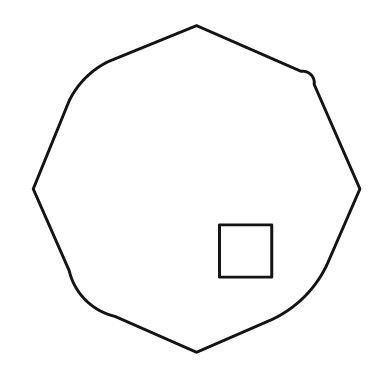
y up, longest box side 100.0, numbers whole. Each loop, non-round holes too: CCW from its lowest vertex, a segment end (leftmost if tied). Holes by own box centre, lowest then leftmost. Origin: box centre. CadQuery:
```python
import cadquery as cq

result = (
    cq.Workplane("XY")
    .moveTo(0.0, -50.0)
    .lineTo(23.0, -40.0)
    .threePointArc((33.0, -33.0), (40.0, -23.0))
    .lineTo(50.0, 0.0)
    .lineTo(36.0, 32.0)
    .threePointArc((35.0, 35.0), (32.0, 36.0))
    .lineTo(0.0, 50.0)
    .lineTo(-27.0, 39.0)
    .threePointArc((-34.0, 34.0), (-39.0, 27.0))
    .lineTo(-50.0, 0.0)
    .lineTo(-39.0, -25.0)
    .threePointArc((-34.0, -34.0), (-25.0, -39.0))
    .close()
    .moveTo(7.0, -27.0)
    .lineTo(23.0, -27.0)
    .lineTo(23.0, -11.0)
    .lineTo(7.0, -11.0)
    .close()
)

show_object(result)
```